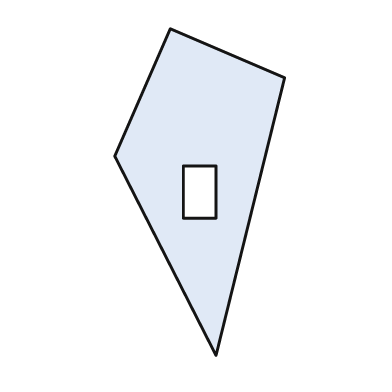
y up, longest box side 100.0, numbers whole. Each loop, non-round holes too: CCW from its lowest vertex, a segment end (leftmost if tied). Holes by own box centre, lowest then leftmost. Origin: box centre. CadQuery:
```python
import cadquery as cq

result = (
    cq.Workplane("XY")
    .moveTo(5.0, -50.0)
    .lineTo(26.0, 35.0)
    .lineTo(-9.0, 50.0)
    .lineTo(-26.0, 11.0)
    .close()
    .moveTo(-5.0, -8.0)
    .lineTo(5.0, -8.0)
    .lineTo(5.0, 8.0)
    .lineTo(-5.0, 8.0)
    .close()
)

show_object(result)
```